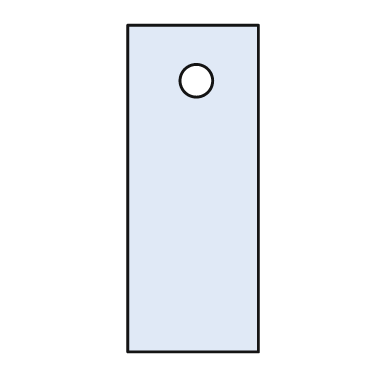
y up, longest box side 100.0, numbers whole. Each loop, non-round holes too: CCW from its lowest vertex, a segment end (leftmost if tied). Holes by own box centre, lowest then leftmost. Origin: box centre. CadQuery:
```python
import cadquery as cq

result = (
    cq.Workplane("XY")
    .moveTo(-20.0, -50.0)
    .lineTo(20.0, -50.0)
    .lineTo(20.0, 50.0)
    .lineTo(-20.0, 50.0)
    .close()
    .moveTo(1.0, 33.0)
    .circle(5.0)
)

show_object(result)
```